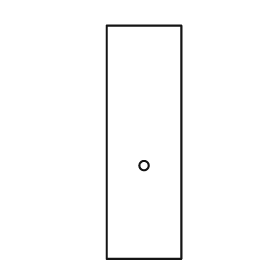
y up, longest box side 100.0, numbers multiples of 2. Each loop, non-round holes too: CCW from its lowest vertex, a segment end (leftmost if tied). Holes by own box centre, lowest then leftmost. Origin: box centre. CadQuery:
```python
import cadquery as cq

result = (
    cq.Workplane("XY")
    .moveTo(-16.0, -50.0)
    .lineTo(16.0, -50.0)
    .lineTo(16.0, 50.0)
    .lineTo(-16.0, 50.0)
    .close()
    .moveTo(0.0, -10.0)
    .circle(2.0)
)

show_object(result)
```